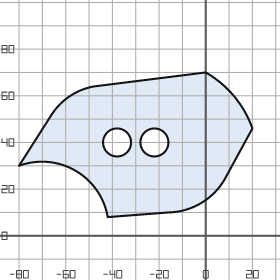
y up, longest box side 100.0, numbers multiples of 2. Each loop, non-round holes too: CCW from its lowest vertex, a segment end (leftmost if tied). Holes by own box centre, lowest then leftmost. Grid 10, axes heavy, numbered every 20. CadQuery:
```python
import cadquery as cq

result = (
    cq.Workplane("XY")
    .moveTo(-42.0, 8.0)
    .lineTo(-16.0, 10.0)
    .threePointArc((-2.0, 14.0), (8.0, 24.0))
    .lineTo(20.0, 46.0)
    .threePointArc((12.0, 60.0), (0.0, 70.0))
    .lineTo(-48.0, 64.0)
    .threePointArc((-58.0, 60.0), (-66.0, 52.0))
    .lineTo(-80.0, 30.0)
    .threePointArc((-56.0, 28.0), (-42.0, 8.0))
    .close()
    .moveTo(-38.0, 40.0)
    .circle(6.0)
    .moveTo(-22.0, 40.0)
    .circle(6.0)
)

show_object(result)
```